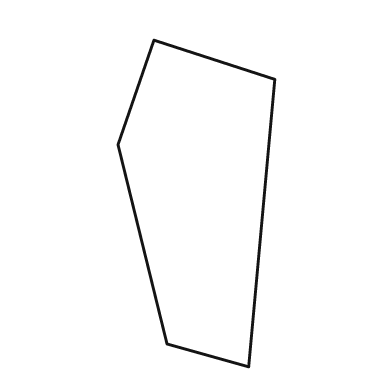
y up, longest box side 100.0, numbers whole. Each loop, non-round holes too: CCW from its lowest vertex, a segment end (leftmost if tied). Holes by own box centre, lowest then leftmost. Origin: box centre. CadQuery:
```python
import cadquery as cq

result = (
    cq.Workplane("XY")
    .moveTo(16.0, -50.0)
    .lineTo(24.0, 38.0)
    .lineTo(-13.0, 50.0)
    .lineTo(-24.0, 18.0)
    .lineTo(-9.0, -43.0)
    .close()
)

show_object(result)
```